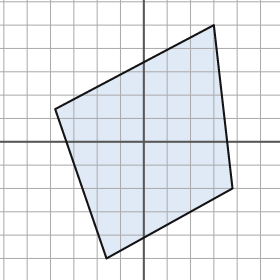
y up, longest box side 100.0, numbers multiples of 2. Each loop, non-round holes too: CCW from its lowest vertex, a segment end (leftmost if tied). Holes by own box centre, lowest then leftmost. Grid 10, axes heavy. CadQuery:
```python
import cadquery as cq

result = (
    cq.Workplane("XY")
    .moveTo(-16.0, -50.0)
    .lineTo(38.0, -20.0)
    .lineTo(30.0, 50.0)
    .lineTo(-38.0, 14.0)
    .close()
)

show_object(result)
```